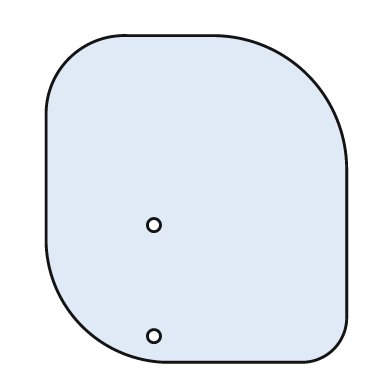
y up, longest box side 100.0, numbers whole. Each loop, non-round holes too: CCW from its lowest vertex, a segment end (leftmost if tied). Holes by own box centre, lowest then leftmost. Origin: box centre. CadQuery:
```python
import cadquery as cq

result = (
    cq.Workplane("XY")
    .moveTo(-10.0, -50.0)
    .lineTo(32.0, -50.0)
    .threePointArc((42.0, -46.0), (46.0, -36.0))
    .lineTo(46.0, 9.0)
    .threePointArc((34.0, 38.0), (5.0, 50.0))
    .lineTo(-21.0, 50.0)
    .threePointArc((-39.0, 43.0), (-46.0, 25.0))
    .lineTo(-46.0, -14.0)
    .threePointArc((-35.0, -39.0), (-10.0, -50.0))
    .close()
    .moveTo(-13.0, -42.0)
    .circle(2.0)
    .moveTo(-13.0, -8.0)
    .circle(2.0)
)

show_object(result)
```